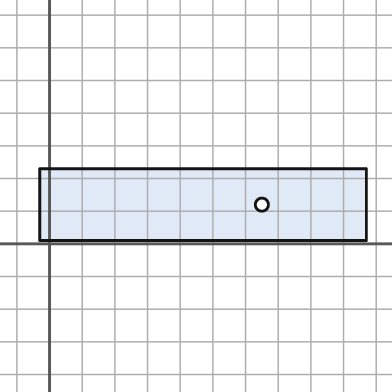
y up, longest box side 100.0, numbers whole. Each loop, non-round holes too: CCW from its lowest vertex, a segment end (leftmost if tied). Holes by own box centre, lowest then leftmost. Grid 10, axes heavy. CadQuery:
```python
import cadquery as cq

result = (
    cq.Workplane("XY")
    .moveTo(-3.0, 1.0)
    .lineTo(97.0, 1.0)
    .lineTo(97.0, 23.0)
    .lineTo(-3.0, 23.0)
    .close()
    .moveTo(65.0, 12.0)
    .circle(2.0)
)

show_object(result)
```